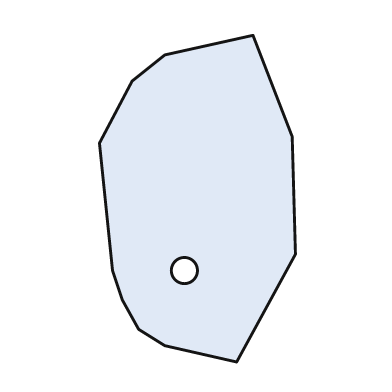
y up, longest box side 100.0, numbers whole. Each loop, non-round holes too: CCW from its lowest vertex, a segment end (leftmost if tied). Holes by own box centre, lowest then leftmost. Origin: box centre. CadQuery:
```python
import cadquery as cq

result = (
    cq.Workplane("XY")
    .moveTo(12.0, -50.0)
    .lineTo(30.0, -17.0)
    .lineTo(29.0, 19.0)
    .lineTo(17.0, 50.0)
    .lineTo(-10.0, 44.0)
    .lineTo(-20.0, 36.0)
    .lineTo(-30.0, 17.0)
    .lineTo(-26.0, -22.0)
    .lineTo(-23.0, -31.0)
    .lineTo(-18.0, -40.0)
    .lineTo(-10.0, -45.0)
    .close()
    .moveTo(-4.0, -22.0)
    .circle(4.0)
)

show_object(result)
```